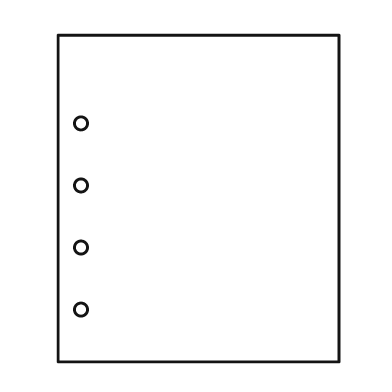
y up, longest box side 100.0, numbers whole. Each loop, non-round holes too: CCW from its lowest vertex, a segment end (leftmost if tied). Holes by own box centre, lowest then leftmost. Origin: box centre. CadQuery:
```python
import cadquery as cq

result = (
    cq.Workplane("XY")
    .moveTo(-43.0, -50.0)
    .lineTo(43.0, -50.0)
    .lineTo(43.0, 50.0)
    .lineTo(-43.0, 50.0)
    .close()
    .moveTo(-36.0, -34.0)
    .circle(2.0)
    .moveTo(-36.0, -15.0)
    .circle(2.0)
    .moveTo(-36.0, 4.0)
    .circle(2.0)
    .moveTo(-36.0, 23.0)
    .circle(2.0)
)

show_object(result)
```